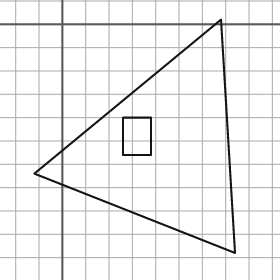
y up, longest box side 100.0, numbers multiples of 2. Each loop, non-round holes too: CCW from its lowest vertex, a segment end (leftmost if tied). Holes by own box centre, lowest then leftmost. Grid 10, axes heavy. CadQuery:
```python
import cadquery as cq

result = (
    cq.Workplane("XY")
    .moveTo(74.0, -98.0)
    .lineTo(68.0, 2.0)
    .lineTo(-12.0, -64.0)
    .close()
    .moveTo(26.0, -56.0)
    .lineTo(38.0, -56.0)
    .lineTo(38.0, -40.0)
    .lineTo(26.0, -40.0)
    .close()
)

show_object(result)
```